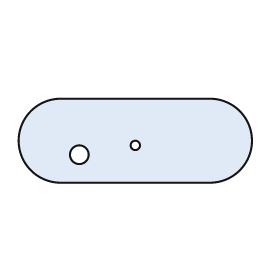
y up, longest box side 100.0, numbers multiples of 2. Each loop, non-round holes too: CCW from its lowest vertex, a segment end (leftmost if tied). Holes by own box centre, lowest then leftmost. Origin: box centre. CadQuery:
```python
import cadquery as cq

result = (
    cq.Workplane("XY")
    .moveTo(-32.0, -18.0)
    .lineTo(32.0, -18.0)
    .threePointArc((50.0, 0.0), (32.0, 18.0))
    .lineTo(-32.0, 18.0)
    .threePointArc((-50.0, 0.0), (-32.0, -18.0))
    .close()
    .moveTo(-24.0, -6.0)
    .circle(4.0)
    .moveTo(0.0, -2.0)
    .circle(2.0)
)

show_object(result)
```